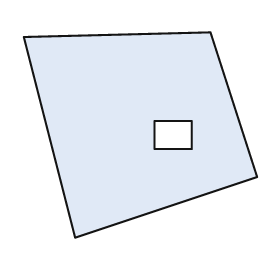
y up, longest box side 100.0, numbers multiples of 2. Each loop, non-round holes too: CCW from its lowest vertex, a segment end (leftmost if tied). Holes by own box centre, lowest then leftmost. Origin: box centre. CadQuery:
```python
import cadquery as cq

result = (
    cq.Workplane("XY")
    .moveTo(-28.0, -44.0)
    .lineTo(50.0, -18.0)
    .lineTo(30.0, 44.0)
    .lineTo(-50.0, 42.0)
    .close()
    .moveTo(6.0, -6.0)
    .lineTo(22.0, -6.0)
    .lineTo(22.0, 6.0)
    .lineTo(6.0, 6.0)
    .close()
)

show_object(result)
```